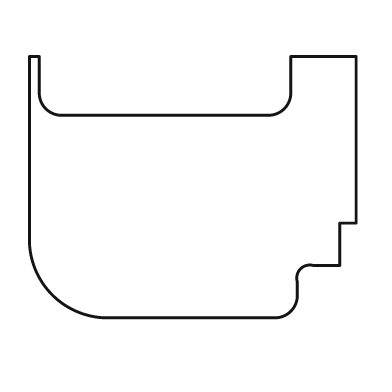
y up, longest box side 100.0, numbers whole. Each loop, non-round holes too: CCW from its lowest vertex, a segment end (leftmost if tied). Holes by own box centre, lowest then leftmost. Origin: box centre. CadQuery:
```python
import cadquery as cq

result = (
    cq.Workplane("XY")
    .moveTo(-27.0, -40.0)
    .lineTo(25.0, -40.0)
    .threePointArc((30.0, -38.0), (32.0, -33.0))
    .lineTo(32.0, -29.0)
    .threePointArc((33.0, -25.0), (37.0, -24.0))
    .lineTo(45.0, -24.0)
    .lineTo(45.0, -11.0)
    .lineTo(50.0, -11.0)
    .lineTo(50.0, 40.0)
    .lineTo(30.0, 40.0)
    .lineTo(30.0, 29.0)
    .threePointArc((28.0, 24.0), (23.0, 22.0))
    .lineTo(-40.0, 22.0)
    .threePointArc((-45.0, 24.0), (-47.0, 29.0))
    .lineTo(-47.0, 40.0)
    .lineTo(-50.0, 40.0)
    .lineTo(-50.0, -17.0)
    .threePointArc((-43.0, -33.0), (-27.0, -40.0))
    .close()
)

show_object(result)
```